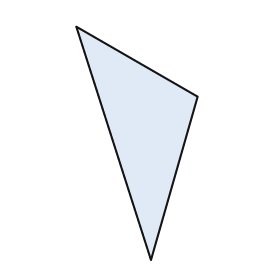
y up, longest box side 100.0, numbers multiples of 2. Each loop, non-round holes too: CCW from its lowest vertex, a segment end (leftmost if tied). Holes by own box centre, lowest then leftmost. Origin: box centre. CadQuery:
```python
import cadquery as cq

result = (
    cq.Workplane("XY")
    .moveTo(6.0, -50.0)
    .lineTo(26.0, 20.0)
    .lineTo(-26.0, 50.0)
    .close()
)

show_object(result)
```